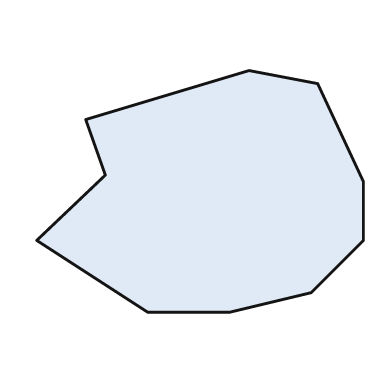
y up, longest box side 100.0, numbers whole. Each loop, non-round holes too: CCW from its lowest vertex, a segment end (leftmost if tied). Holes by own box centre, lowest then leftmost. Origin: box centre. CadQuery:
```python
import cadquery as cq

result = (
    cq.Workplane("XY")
    .moveTo(-16.0, -37.0)
    .lineTo(9.0, -37.0)
    .lineTo(34.0, -31.0)
    .lineTo(50.0, -15.0)
    .lineTo(50.0, 3.0)
    .lineTo(36.0, 33.0)
    .lineTo(15.0, 37.0)
    .lineTo(-35.0, 22.0)
    .lineTo(-29.0, 5.0)
    .lineTo(-50.0, -15.0)
    .close()
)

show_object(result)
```